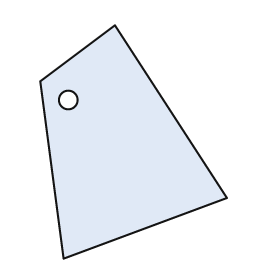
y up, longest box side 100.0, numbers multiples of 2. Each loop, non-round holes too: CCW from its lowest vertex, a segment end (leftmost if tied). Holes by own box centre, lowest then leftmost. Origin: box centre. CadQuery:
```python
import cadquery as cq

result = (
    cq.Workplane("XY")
    .moveTo(-30.0, -50.0)
    .lineTo(40.0, -24.0)
    .lineTo(-8.0, 50.0)
    .lineTo(-40.0, 26.0)
    .close()
    .moveTo(-28.0, 18.0)
    .circle(4.0)
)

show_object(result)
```